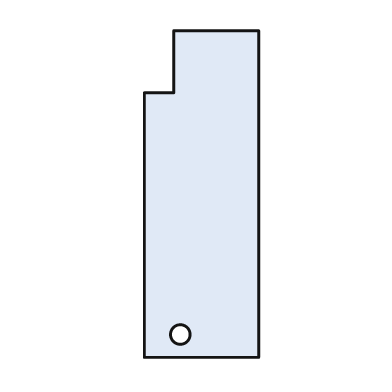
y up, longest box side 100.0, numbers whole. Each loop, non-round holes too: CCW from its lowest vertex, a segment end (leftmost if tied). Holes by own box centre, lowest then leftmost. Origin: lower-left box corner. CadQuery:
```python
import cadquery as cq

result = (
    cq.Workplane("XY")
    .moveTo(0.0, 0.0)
    .lineTo(35.0, 0.0)
    .lineTo(35.0, 100.0)
    .lineTo(9.0, 100.0)
    .lineTo(9.0, 81.0)
    .lineTo(0.0, 81.0)
    .close()
    .moveTo(11.0, 7.0)
    .circle(3.0)
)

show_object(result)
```